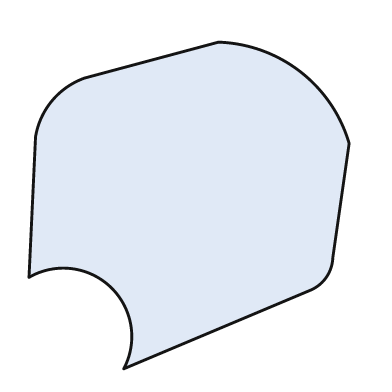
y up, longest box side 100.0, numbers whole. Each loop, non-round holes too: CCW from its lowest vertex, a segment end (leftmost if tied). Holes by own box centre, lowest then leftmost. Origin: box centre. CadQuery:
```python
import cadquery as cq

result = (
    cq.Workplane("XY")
    .moveTo(-20.0, -50.0)
    .lineTo(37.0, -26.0)
    .threePointArc((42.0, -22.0), (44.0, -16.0))
    .lineTo(49.0, 19.0)
    .threePointArc((34.0, 41.0), (9.0, 50.0))
    .lineTo(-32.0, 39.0)
    .threePointArc((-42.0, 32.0), (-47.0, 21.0))
    .lineTo(-49.0, -22.0)
    .threePointArc((-24.0, -25.0), (-20.0, -50.0))
    .close()
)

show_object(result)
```